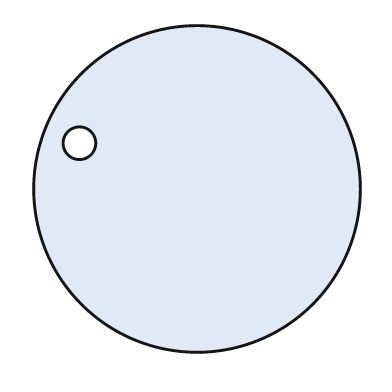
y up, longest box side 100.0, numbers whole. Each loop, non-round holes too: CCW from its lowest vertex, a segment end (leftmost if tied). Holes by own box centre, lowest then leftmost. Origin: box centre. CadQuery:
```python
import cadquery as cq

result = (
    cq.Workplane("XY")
    .moveTo(0.0, 0.0)
    .circle(50.0)
    .moveTo(-36.0, 14.0)
    .circle(5.0)
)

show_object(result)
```